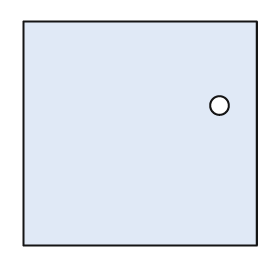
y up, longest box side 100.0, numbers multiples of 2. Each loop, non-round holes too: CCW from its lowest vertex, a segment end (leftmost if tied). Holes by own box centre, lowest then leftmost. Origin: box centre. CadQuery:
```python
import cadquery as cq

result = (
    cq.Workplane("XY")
    .moveTo(-50.0, -48.0)
    .lineTo(50.0, -48.0)
    .lineTo(50.0, 48.0)
    .lineTo(-50.0, 48.0)
    .close()
    .moveTo(34.0, 12.0)
    .circle(4.0)
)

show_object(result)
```